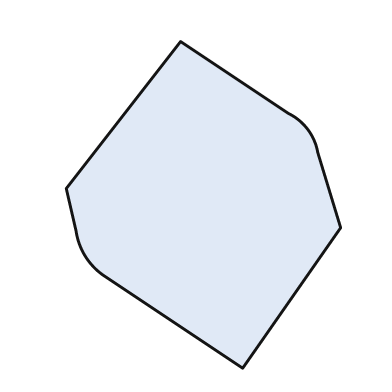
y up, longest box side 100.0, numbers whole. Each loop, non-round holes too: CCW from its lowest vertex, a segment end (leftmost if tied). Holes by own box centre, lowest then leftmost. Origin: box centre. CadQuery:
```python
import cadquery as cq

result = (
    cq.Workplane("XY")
    .moveTo(12.0, -50.0)
    .lineTo(42.0, -7.0)
    .lineTo(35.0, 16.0)
    .threePointArc((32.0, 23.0), (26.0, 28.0))
    .lineTo(-7.0, 50.0)
    .lineTo(-42.0, 5.0)
    .lineTo(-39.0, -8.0)
    .threePointArc((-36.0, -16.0), (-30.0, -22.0))
    .close()
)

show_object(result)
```